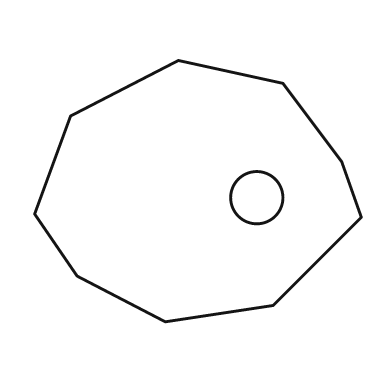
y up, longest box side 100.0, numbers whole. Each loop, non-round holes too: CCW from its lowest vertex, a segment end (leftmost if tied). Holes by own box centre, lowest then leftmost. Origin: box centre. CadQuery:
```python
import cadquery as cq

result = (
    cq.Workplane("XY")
    .moveTo(-10.0, -40.0)
    .lineTo(23.0, -35.0)
    .lineTo(50.0, -8.0)
    .lineTo(44.0, 9.0)
    .lineTo(26.0, 33.0)
    .lineTo(-6.0, 40.0)
    .lineTo(-39.0, 23.0)
    .lineTo(-50.0, -7.0)
    .lineTo(-37.0, -26.0)
    .close()
    .moveTo(18.0, -2.0)
    .circle(8.0)
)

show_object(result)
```